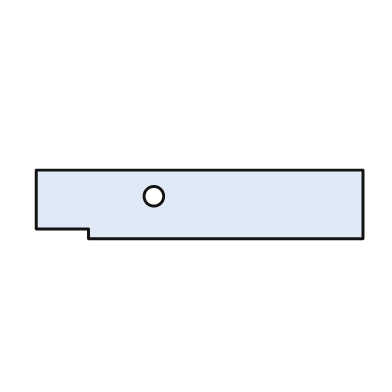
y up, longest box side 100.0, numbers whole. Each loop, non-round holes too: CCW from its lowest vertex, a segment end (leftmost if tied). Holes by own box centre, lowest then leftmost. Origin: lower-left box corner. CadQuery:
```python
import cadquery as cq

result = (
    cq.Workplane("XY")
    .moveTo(16.0, 0.0)
    .lineTo(100.0, 0.0)
    .lineTo(100.0, 21.0)
    .lineTo(0.0, 21.0)
    .lineTo(0.0, 3.0)
    .lineTo(16.0, 3.0)
    .close()
    .moveTo(36.0, 13.0)
    .circle(3.0)
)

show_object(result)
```